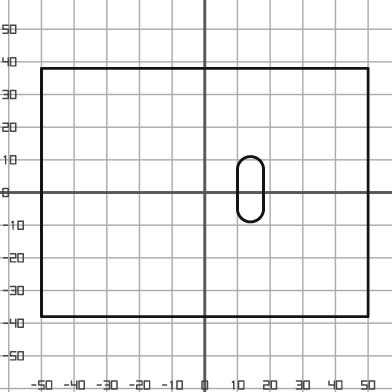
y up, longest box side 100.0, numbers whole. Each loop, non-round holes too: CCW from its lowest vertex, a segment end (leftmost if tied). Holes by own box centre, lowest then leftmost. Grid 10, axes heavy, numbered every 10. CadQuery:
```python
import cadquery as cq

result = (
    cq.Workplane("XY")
    .moveTo(-50.0, -38.0)
    .lineTo(50.0, -38.0)
    .lineTo(50.0, 38.0)
    .lineTo(-50.0, 38.0)
    .close()
    .moveTo(10.0, -5.0)
    .threePointArc((14.0, -9.0), (18.0, -5.0))
    .lineTo(18.0, 7.0)
    .threePointArc((14.0, 11.0), (10.0, 7.0))
    .close()
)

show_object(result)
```